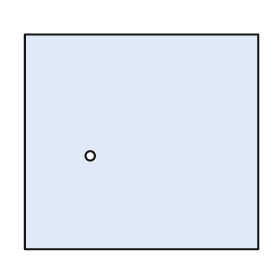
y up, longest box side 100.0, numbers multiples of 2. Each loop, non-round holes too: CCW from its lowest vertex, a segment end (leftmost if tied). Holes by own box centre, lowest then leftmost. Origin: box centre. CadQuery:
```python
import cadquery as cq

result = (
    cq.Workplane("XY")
    .moveTo(-50.0, -46.0)
    .lineTo(50.0, -46.0)
    .lineTo(50.0, 46.0)
    .lineTo(-50.0, 46.0)
    .close()
    .moveTo(-22.0, -6.0)
    .circle(2.0)
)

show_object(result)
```